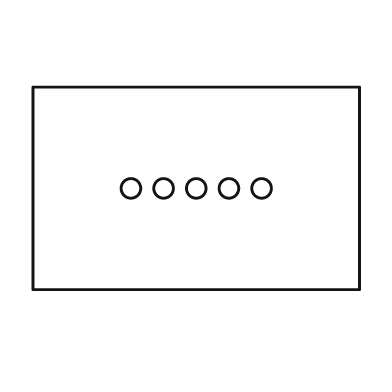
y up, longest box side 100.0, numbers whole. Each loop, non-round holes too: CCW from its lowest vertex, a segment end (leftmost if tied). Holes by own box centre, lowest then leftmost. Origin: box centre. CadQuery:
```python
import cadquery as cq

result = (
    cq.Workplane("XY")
    .moveTo(-50.0, -31.0)
    .lineTo(50.0, -31.0)
    .lineTo(50.0, 31.0)
    .lineTo(-50.0, 31.0)
    .close()
    .moveTo(-20.0, 0.0)
    .circle(3.0)
    .moveTo(-10.0, 0.0)
    .circle(3.0)
    .moveTo(0.0, 0.0)
    .circle(3.0)
    .moveTo(10.0, 0.0)
    .circle(3.0)
    .moveTo(20.0, 0.0)
    .circle(3.0)
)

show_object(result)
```